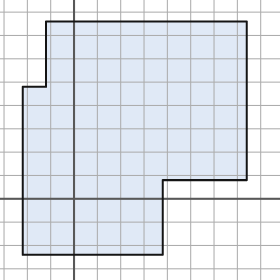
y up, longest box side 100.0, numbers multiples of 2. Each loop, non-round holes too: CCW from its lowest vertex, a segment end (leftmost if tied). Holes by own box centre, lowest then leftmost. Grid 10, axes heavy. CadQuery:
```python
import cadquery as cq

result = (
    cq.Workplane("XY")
    .moveTo(-22.0, -24.0)
    .lineTo(38.0, -24.0)
    .lineTo(38.0, 8.0)
    .lineTo(74.0, 8.0)
    .lineTo(74.0, 76.0)
    .lineTo(-12.0, 76.0)
    .lineTo(-12.0, 48.0)
    .lineTo(-22.0, 48.0)
    .close()
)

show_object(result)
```